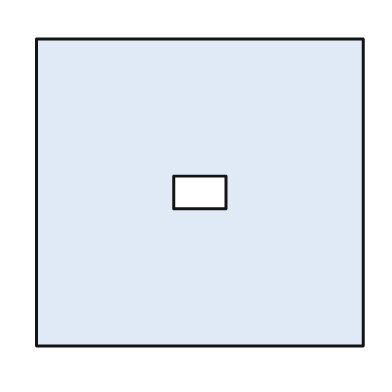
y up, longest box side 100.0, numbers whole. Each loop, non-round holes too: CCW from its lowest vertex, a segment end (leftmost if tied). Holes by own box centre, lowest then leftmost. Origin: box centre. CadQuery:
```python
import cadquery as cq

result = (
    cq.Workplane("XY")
    .moveTo(-50.0, -47.0)
    .lineTo(50.0, -47.0)
    .lineTo(50.0, 47.0)
    .lineTo(-50.0, 47.0)
    .close()
    .moveTo(-8.0, -5.0)
    .lineTo(8.0, -5.0)
    .lineTo(8.0, 5.0)
    .lineTo(-8.0, 5.0)
    .close()
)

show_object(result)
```